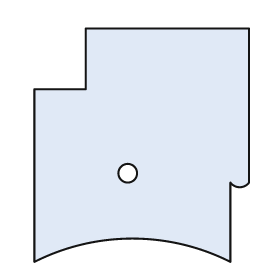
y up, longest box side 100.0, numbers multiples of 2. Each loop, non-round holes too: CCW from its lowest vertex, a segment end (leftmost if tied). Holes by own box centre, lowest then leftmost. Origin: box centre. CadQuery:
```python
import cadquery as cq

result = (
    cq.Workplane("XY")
    .moveTo(-46.0, -50.0)
    .threePointArc((-4.0, -40.0), (38.0, -50.0))
    .lineTo(38.0, -16.0)
    .threePointArc((42.0, -18.0), (46.0, -16.0))
    .lineTo(46.0, 50.0)
    .lineTo(-24.0, 50.0)
    .lineTo(-24.0, 24.0)
    .lineTo(-46.0, 24.0)
    .close()
    .moveTo(-6.0, -12.0)
    .circle(4.0)
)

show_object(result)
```